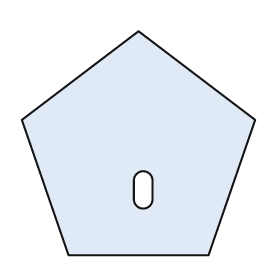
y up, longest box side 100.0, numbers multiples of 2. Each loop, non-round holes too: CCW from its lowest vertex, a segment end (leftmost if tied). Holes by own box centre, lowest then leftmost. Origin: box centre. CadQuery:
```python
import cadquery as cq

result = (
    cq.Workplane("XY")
    .moveTo(-30.0, -48.0)
    .lineTo(30.0, -48.0)
    .lineTo(50.0, 10.0)
    .lineTo(0.0, 48.0)
    .lineTo(-50.0, 10.0)
    .close()
    .moveTo(-2.0, -24.0)
    .threePointArc((2.0, -28.0), (6.0, -24.0))
    .lineTo(6.0, -16.0)
    .threePointArc((2.0, -12.0), (-2.0, -16.0))
    .close()
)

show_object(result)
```